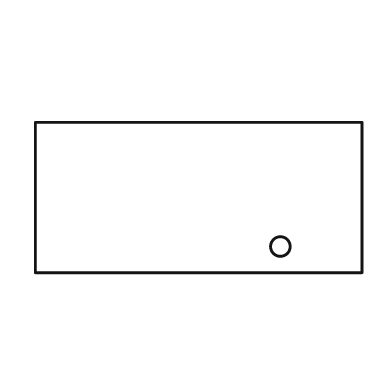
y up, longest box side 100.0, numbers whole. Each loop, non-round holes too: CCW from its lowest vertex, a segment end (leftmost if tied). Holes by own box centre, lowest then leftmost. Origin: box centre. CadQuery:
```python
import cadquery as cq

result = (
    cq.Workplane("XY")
    .moveTo(-50.0, -23.0)
    .lineTo(50.0, -23.0)
    .lineTo(50.0, 23.0)
    .lineTo(-50.0, 23.0)
    .close()
    .moveTo(25.0, -15.0)
    .circle(3.0)
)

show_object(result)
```